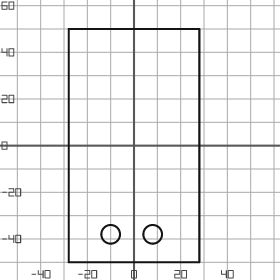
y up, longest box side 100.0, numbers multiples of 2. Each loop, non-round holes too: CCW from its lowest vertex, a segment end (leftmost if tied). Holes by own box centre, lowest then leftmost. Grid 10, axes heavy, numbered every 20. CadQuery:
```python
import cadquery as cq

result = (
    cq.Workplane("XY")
    .moveTo(-28.0, -50.0)
    .lineTo(28.0, -50.0)
    .lineTo(28.0, 50.0)
    .lineTo(-28.0, 50.0)
    .close()
    .moveTo(-10.0, -38.0)
    .circle(4.0)
    .moveTo(8.0, -38.0)
    .circle(4.0)
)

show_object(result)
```